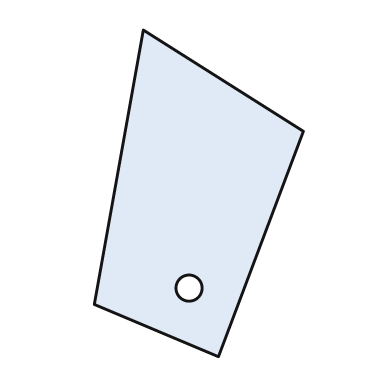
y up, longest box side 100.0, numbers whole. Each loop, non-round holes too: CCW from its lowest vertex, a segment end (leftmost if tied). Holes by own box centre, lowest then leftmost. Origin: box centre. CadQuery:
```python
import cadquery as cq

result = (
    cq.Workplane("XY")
    .moveTo(6.0, -50.0)
    .lineTo(32.0, 19.0)
    .lineTo(-17.0, 50.0)
    .lineTo(-32.0, -34.0)
    .close()
    .moveTo(-3.0, -29.0)
    .circle(4.0)
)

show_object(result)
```